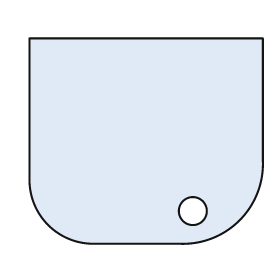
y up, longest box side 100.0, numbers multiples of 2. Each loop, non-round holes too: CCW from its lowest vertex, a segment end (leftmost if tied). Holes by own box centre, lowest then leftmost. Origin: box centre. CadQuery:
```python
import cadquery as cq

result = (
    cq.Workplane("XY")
    .moveTo(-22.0, -44.0)
    .lineTo(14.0, -44.0)
    .threePointArc((40.0, -34.0), (50.0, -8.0))
    .lineTo(50.0, 44.0)
    .lineTo(-50.0, 44.0)
    .lineTo(-50.0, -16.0)
    .threePointArc((-42.0, -36.0), (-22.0, -44.0))
    .close()
    .moveTo(20.0, -30.0)
    .circle(6.0)
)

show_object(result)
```